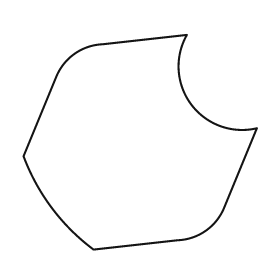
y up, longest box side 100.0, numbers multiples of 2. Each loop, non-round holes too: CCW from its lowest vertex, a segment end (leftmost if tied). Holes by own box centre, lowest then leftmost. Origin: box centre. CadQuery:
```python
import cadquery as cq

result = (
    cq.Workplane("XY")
    .moveTo(-20.0, -46.0)
    .lineTo(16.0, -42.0)
    .threePointArc((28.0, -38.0), (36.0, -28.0))
    .lineTo(50.0, 6.0)
    .threePointArc((22.0, 16.0), (20.0, 46.0))
    .lineTo(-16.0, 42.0)
    .threePointArc((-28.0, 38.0), (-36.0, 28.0))
    .lineTo(-50.0, -6.0)
    .threePointArc((-38.0, -28.0), (-20.0, -46.0))
    .close()
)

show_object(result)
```